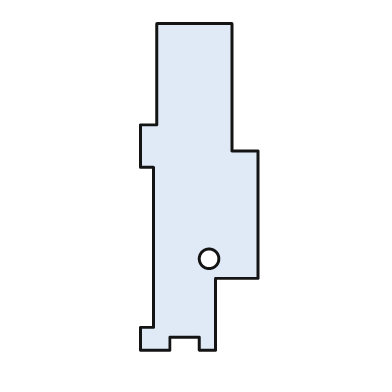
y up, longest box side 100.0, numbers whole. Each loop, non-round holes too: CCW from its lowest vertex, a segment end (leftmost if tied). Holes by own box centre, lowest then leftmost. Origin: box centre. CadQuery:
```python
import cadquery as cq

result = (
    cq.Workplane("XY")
    .moveTo(-18.0, -50.0)
    .lineTo(-9.0, -50.0)
    .lineTo(-9.0, -46.0)
    .lineTo(0.0, -46.0)
    .lineTo(0.0, -50.0)
    .lineTo(5.0, -50.0)
    .lineTo(5.0, -28.0)
    .lineTo(18.0, -28.0)
    .lineTo(18.0, 11.0)
    .lineTo(10.0, 11.0)
    .lineTo(10.0, 50.0)
    .lineTo(-13.0, 50.0)
    .lineTo(-13.0, 19.0)
    .lineTo(-18.0, 19.0)
    .lineTo(-18.0, 6.0)
    .lineTo(-14.0, 6.0)
    .lineTo(-14.0, -43.0)
    .lineTo(-18.0, -43.0)
    .close()
    .moveTo(3.0, -22.0)
    .circle(3.0)
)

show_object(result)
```